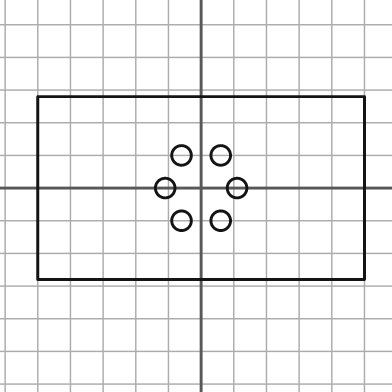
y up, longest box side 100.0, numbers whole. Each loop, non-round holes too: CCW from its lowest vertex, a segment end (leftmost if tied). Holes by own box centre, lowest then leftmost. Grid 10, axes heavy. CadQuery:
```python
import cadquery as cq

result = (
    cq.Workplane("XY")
    .moveTo(-50.0, -28.0)
    .lineTo(50.0, -28.0)
    .lineTo(50.0, 28.0)
    .lineTo(-50.0, 28.0)
    .close()
    .moveTo(-6.0, -10.0)
    .circle(3.0)
    .moveTo(6.0, -10.0)
    .circle(3.0)
    .moveTo(-11.0, 0.0)
    .circle(3.0)
    .moveTo(11.0, 0.0)
    .circle(3.0)
    .moveTo(-6.0, 10.0)
    .circle(3.0)
    .moveTo(6.0, 10.0)
    .circle(3.0)
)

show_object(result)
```